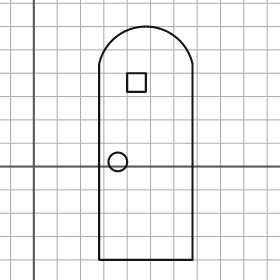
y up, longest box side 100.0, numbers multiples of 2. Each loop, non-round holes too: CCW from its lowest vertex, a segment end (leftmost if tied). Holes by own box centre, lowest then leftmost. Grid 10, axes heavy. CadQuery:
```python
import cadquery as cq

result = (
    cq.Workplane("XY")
    .moveTo(28.0, -40.0)
    .lineTo(68.0, -40.0)
    .lineTo(68.0, 44.0)
    .threePointArc((48.0, 60.0), (28.0, 44.0))
    .close()
    .moveTo(36.0, 2.0)
    .circle(4.0)
    .moveTo(40.0, 32.0)
    .lineTo(48.0, 32.0)
    .lineTo(48.0, 40.0)
    .lineTo(40.0, 40.0)
    .close()
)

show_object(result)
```